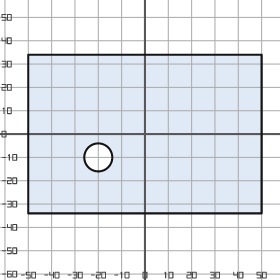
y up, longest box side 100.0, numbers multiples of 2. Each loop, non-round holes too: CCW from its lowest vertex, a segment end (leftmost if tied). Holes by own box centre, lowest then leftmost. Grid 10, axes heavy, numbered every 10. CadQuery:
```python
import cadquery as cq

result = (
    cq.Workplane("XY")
    .moveTo(-50.0, -34.0)
    .lineTo(50.0, -34.0)
    .lineTo(50.0, 34.0)
    .lineTo(-50.0, 34.0)
    .close()
    .moveTo(-20.0, -10.0)
    .circle(6.0)
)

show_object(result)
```